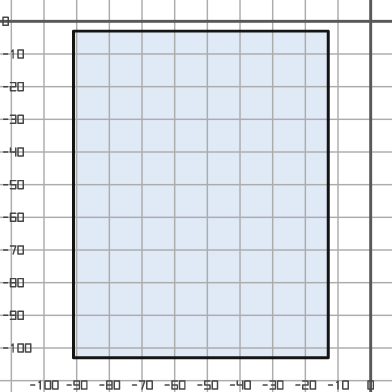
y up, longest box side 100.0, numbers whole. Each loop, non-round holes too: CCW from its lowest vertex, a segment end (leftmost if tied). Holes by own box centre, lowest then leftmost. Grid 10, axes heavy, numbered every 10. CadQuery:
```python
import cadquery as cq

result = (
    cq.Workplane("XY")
    .moveTo(-91.0, -103.0)
    .lineTo(-13.0, -103.0)
    .lineTo(-13.0, -3.0)
    .lineTo(-91.0, -3.0)
    .close()
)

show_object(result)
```